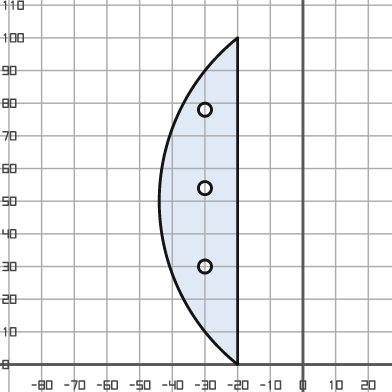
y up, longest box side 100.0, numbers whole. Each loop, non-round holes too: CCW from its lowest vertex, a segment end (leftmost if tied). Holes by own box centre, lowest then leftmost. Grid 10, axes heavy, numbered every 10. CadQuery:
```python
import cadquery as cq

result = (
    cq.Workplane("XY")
    .moveTo(-20.0, 0.0)
    .lineTo(-20.0, 100.0)
    .threePointArc((-44.0, 50.0), (-20.0, 0.0))
    .close()
    .moveTo(-30.0, 30.0)
    .circle(2.0)
    .moveTo(-30.0, 54.0)
    .circle(2.0)
    .moveTo(-30.0, 78.0)
    .circle(2.0)
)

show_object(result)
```